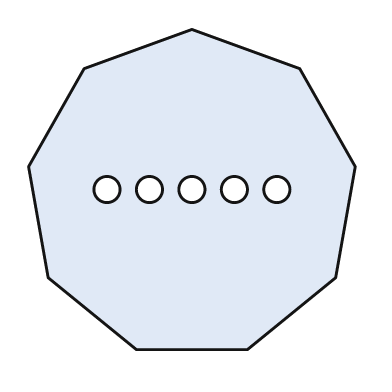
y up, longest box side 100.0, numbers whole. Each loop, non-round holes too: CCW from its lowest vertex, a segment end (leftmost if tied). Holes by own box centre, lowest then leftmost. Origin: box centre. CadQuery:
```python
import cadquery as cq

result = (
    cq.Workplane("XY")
    .moveTo(-17.0, -49.0)
    .lineTo(17.0, -49.0)
    .lineTo(44.0, -27.0)
    .lineTo(50.0, 7.0)
    .lineTo(33.0, 37.0)
    .lineTo(0.0, 49.0)
    .lineTo(-33.0, 37.0)
    .lineTo(-50.0, 7.0)
    .lineTo(-44.0, -27.0)
    .close()
    .moveTo(-26.0, 0.0)
    .circle(4.0)
    .moveTo(-13.0, 0.0)
    .circle(4.0)
    .moveTo(0.0, 0.0)
    .circle(4.0)
    .moveTo(13.0, 0.0)
    .circle(4.0)
    .moveTo(26.0, 0.0)
    .circle(4.0)
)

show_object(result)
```